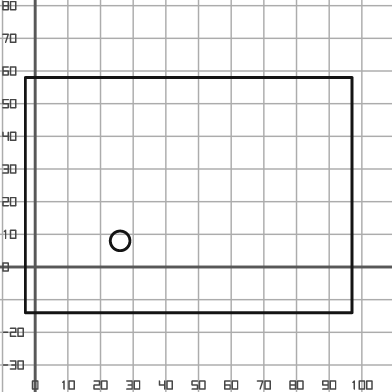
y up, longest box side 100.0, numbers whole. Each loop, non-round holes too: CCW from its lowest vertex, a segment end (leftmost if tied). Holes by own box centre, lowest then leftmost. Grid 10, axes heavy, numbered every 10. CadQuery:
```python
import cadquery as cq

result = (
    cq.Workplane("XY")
    .moveTo(-3.0, -14.0)
    .lineTo(97.0, -14.0)
    .lineTo(97.0, 58.0)
    .lineTo(-3.0, 58.0)
    .close()
    .moveTo(26.0, 8.0)
    .circle(3.0)
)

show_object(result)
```